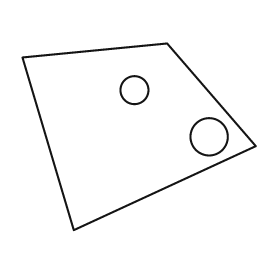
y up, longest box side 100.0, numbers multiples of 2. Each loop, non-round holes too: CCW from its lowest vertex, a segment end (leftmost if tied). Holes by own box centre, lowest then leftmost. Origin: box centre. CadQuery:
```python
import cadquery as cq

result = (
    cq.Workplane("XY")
    .moveTo(-28.0, -40.0)
    .lineTo(50.0, -4.0)
    .lineTo(12.0, 40.0)
    .lineTo(-50.0, 34.0)
    .close()
    .moveTo(30.0, 0.0)
    .circle(8.0)
    .moveTo(-2.0, 20.0)
    .circle(6.0)
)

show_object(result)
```